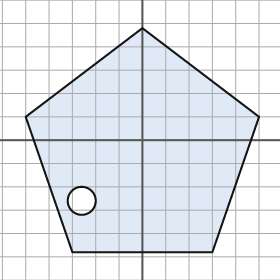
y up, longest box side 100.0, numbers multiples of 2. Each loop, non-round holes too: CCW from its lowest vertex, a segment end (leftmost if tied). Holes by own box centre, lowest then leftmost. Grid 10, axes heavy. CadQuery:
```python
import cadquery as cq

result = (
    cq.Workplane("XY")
    .moveTo(-30.0, -48.0)
    .lineTo(30.0, -48.0)
    .lineTo(50.0, 10.0)
    .lineTo(0.0, 48.0)
    .lineTo(-50.0, 10.0)
    .close()
    .moveTo(-26.0, -26.0)
    .circle(6.0)
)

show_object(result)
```